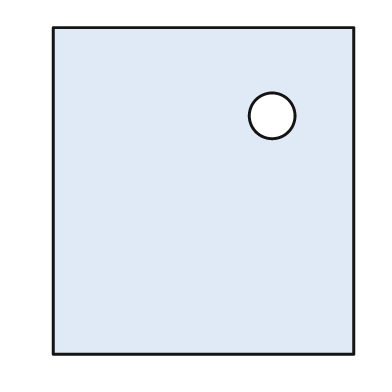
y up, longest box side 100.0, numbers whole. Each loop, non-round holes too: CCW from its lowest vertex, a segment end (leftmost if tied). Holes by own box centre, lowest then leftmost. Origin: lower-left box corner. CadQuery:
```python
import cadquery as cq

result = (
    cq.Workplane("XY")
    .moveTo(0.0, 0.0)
    .lineTo(92.0, 0.0)
    .lineTo(92.0, 100.0)
    .lineTo(0.0, 100.0)
    .close()
    .moveTo(67.0, 73.0)
    .circle(7.0)
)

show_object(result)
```